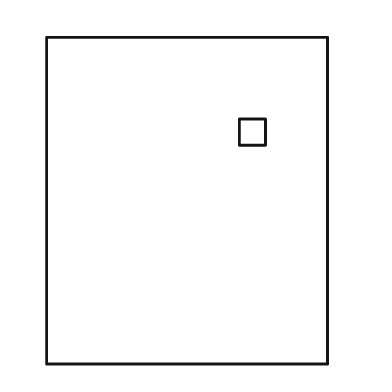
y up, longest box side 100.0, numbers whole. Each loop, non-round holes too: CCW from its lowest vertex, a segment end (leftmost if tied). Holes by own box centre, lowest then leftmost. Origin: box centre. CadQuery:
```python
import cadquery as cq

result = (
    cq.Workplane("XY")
    .moveTo(-43.0, -50.0)
    .lineTo(43.0, -50.0)
    .lineTo(43.0, 50.0)
    .lineTo(-43.0, 50.0)
    .close()
    .moveTo(16.0, 17.0)
    .lineTo(24.0, 17.0)
    .lineTo(24.0, 25.0)
    .lineTo(16.0, 25.0)
    .close()
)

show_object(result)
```